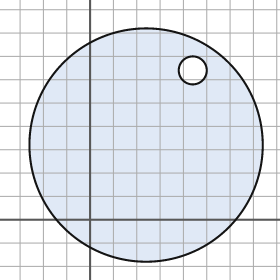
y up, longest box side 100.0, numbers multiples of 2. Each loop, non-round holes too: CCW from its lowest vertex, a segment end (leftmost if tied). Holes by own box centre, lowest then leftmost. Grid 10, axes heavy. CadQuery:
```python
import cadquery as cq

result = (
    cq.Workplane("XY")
    .moveTo(24.0, 32.0)
    .circle(50.0)
    .moveTo(44.0, 64.0)
    .circle(6.0)
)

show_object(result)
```